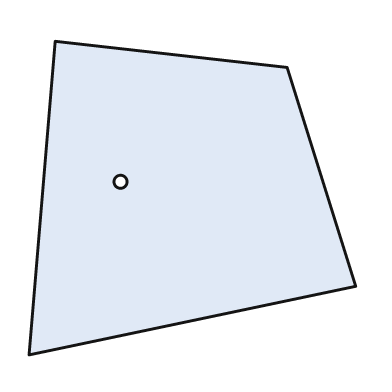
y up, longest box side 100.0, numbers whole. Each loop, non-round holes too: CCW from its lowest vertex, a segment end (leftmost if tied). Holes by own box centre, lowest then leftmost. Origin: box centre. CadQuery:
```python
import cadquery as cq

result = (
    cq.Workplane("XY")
    .moveTo(-50.0, -48.0)
    .lineTo(50.0, -27.0)
    .lineTo(29.0, 40.0)
    .lineTo(-42.0, 48.0)
    .close()
    .moveTo(-22.0, 5.0)
    .circle(2.0)
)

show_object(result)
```